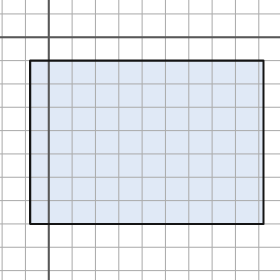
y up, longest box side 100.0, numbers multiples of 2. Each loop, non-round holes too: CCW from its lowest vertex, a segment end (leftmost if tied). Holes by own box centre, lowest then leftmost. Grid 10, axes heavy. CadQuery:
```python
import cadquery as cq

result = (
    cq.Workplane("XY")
    .moveTo(-8.0, -80.0)
    .lineTo(92.0, -80.0)
    .lineTo(92.0, -10.0)
    .lineTo(-8.0, -10.0)
    .close()
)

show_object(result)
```